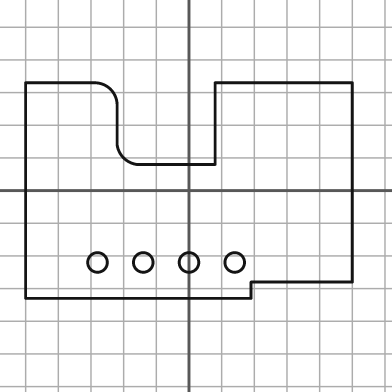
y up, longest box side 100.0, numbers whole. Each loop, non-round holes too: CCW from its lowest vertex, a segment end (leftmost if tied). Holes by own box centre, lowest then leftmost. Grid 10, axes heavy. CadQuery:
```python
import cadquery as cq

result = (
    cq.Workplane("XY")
    .moveTo(-50.0, -33.0)
    .lineTo(19.0, -33.0)
    .lineTo(19.0, -28.0)
    .lineTo(50.0, -28.0)
    .lineTo(50.0, 33.0)
    .lineTo(8.0, 33.0)
    .lineTo(8.0, 8.0)
    .lineTo(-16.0, 8.0)
    .threePointArc((-20.0, 10.0), (-22.0, 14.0))
    .lineTo(-22.0, 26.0)
    .threePointArc((-24.0, 31.0), (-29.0, 33.0))
    .lineTo(-50.0, 33.0)
    .close()
    .moveTo(-28.0, -22.0)
    .circle(3.0)
    .moveTo(-14.0, -22.0)
    .circle(3.0)
    .moveTo(0.0, -22.0)
    .circle(3.0)
    .moveTo(14.0, -22.0)
    .circle(3.0)
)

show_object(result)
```